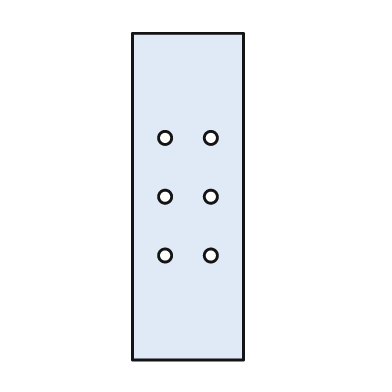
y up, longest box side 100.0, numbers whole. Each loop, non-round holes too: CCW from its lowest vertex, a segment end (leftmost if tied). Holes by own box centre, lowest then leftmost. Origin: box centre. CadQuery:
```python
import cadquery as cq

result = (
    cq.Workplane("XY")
    .moveTo(-17.0, -50.0)
    .lineTo(17.0, -50.0)
    .lineTo(17.0, 50.0)
    .lineTo(-17.0, 50.0)
    .close()
    .moveTo(-7.0, -18.0)
    .circle(2.0)
    .moveTo(7.0, -18.0)
    .circle(2.0)
    .moveTo(-7.0, 0.0)
    .circle(2.0)
    .moveTo(7.0, 0.0)
    .circle(2.0)
    .moveTo(-7.0, 18.0)
    .circle(2.0)
    .moveTo(7.0, 18.0)
    .circle(2.0)
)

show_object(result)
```